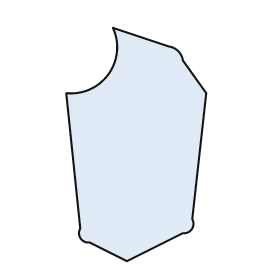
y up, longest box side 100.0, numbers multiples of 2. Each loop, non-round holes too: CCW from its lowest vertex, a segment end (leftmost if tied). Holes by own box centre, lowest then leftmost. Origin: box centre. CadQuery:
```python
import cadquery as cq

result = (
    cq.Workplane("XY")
    .moveTo(-4.0, -50.0)
    .lineTo(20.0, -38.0)
    .threePointArc((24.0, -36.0), (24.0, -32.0))
    .lineTo(30.0, 22.0)
    .lineTo(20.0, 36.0)
    .threePointArc((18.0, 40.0), (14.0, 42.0))
    .lineTo(-10.0, 50.0)
    .threePointArc((-12.0, 30.0), (-30.0, 22.0))
    .lineTo(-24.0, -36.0)
    .threePointArc((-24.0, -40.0), (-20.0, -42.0))
    .close()
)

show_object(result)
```